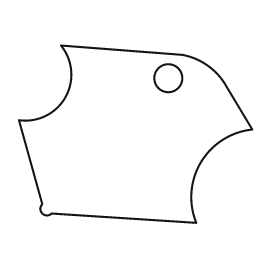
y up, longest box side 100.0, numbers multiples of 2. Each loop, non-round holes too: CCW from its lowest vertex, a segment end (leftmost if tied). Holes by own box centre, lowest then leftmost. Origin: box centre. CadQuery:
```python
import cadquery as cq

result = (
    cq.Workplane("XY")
    .moveTo(26.0, -38.0)
    .threePointArc((28.0, -12.0), (50.0, 2.0))
    .lineTo(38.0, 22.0)
    .threePointArc((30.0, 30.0), (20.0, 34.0))
    .lineTo(-32.0, 38.0)
    .threePointArc((-30.0, 16.0), (-50.0, 6.0))
    .lineTo(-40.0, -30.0)
    .threePointArc((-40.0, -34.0), (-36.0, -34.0))
    .close()
    .moveTo(14.0, 24.0)
    .circle(6.0)
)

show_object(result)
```